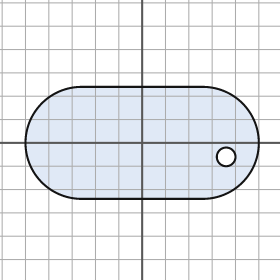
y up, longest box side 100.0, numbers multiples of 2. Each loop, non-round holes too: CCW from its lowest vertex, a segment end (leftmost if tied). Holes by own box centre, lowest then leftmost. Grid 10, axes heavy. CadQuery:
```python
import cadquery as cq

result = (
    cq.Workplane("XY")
    .moveTo(-26.0, -24.0)
    .lineTo(26.0, -24.0)
    .threePointArc((50.0, 0.0), (26.0, 24.0))
    .lineTo(-26.0, 24.0)
    .threePointArc((-50.0, 0.0), (-26.0, -24.0))
    .close()
    .moveTo(36.0, -6.0)
    .circle(4.0)
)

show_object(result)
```